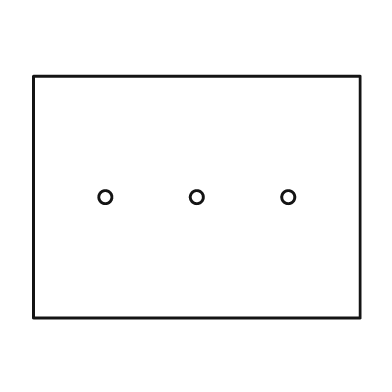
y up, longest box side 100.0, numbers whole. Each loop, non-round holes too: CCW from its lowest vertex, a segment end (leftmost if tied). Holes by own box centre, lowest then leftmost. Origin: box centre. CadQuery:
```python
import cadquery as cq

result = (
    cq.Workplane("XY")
    .moveTo(-50.0, -37.0)
    .lineTo(50.0, -37.0)
    .lineTo(50.0, 37.0)
    .lineTo(-50.0, 37.0)
    .close()
    .moveTo(-28.0, 0.0)
    .circle(2.0)
    .moveTo(0.0, 0.0)
    .circle(2.0)
    .moveTo(28.0, 0.0)
    .circle(2.0)
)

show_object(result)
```